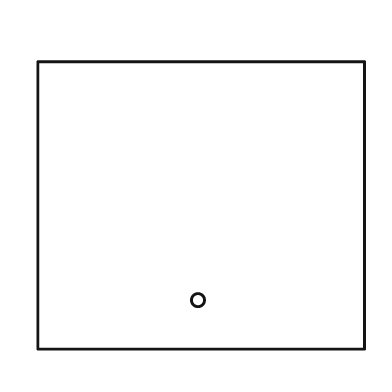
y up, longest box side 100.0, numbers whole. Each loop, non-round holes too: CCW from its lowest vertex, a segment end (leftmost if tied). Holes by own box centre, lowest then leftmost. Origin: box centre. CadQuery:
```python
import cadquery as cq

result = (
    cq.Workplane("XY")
    .moveTo(-50.0, -44.0)
    .lineTo(50.0, -44.0)
    .lineTo(50.0, 44.0)
    .lineTo(-50.0, 44.0)
    .close()
    .moveTo(-1.0, -29.0)
    .circle(2.0)
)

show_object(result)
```